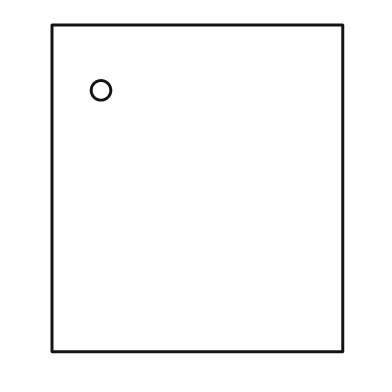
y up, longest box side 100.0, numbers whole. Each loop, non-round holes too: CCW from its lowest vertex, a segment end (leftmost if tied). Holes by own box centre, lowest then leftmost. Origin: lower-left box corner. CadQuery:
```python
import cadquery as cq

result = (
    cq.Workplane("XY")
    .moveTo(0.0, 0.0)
    .lineTo(89.0, 0.0)
    .lineTo(89.0, 100.0)
    .lineTo(0.0, 100.0)
    .close()
    .moveTo(15.0, 80.0)
    .circle(3.0)
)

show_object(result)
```